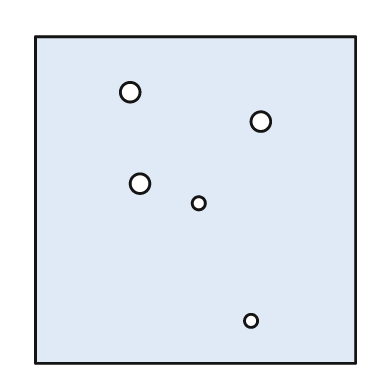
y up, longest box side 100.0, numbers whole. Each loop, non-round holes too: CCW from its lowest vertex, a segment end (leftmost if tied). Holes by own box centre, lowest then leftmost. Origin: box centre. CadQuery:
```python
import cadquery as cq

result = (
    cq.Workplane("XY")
    .moveTo(-49.0, -50.0)
    .lineTo(49.0, -50.0)
    .lineTo(49.0, 50.0)
    .lineTo(-49.0, 50.0)
    .close()
    .moveTo(17.0, -37.0)
    .circle(2.0)
    .moveTo(1.0, -1.0)
    .circle(2.0)
    .moveTo(-17.0, 5.0)
    .circle(3.0)
    .moveTo(20.0, 24.0)
    .circle(3.0)
    .moveTo(-20.0, 33.0)
    .circle(3.0)
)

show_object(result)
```